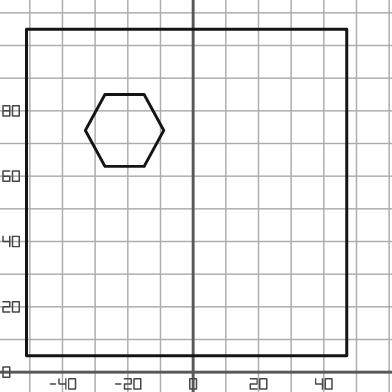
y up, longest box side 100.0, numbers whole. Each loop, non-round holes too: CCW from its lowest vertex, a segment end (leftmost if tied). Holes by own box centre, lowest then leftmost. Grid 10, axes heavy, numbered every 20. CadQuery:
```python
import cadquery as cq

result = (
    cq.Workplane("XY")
    .moveTo(-51.0, 5.0)
    .lineTo(47.0, 5.0)
    .lineTo(47.0, 105.0)
    .lineTo(-51.0, 105.0)
    .close()
    .moveTo(-27.0, 63.0)
    .lineTo(-15.0, 63.0)
    .lineTo(-9.0, 74.0)
    .lineTo(-15.0, 85.0)
    .lineTo(-27.0, 85.0)
    .lineTo(-33.0, 74.0)
    .close()
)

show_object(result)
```